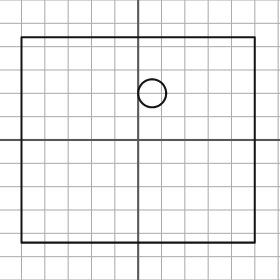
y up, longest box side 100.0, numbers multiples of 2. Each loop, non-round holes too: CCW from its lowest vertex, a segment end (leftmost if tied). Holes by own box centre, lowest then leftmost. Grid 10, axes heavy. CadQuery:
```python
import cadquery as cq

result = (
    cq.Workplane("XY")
    .moveTo(-50.0, -44.0)
    .lineTo(50.0, -44.0)
    .lineTo(50.0, 44.0)
    .lineTo(-50.0, 44.0)
    .close()
    .moveTo(6.0, 20.0)
    .circle(6.0)
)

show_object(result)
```